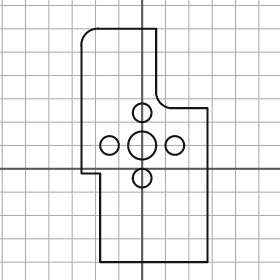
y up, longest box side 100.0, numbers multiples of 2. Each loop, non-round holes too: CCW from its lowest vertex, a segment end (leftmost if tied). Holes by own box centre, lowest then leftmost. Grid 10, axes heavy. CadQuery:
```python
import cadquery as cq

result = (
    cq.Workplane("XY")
    .moveTo(-18.0, -40.0)
    .lineTo(28.0, -40.0)
    .lineTo(28.0, 26.0)
    .lineTo(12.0, 26.0)
    .threePointArc((8.0, 28.0), (6.0, 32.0))
    .lineTo(6.0, 60.0)
    .lineTo(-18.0, 60.0)
    .threePointArc((-24.0, 58.0), (-26.0, 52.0))
    .lineTo(-26.0, -2.0)
    .lineTo(-18.0, -2.0)
    .close()
    .moveTo(0.0, -4.0)
    .circle(4.0)
    .moveTo(-14.0, 10.0)
    .circle(4.0)
    .moveTo(0.0, 10.0)
    .circle(6.0)
    .moveTo(14.0, 10.0)
    .circle(4.0)
    .moveTo(0.0, 24.0)
    .circle(4.0)
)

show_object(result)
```